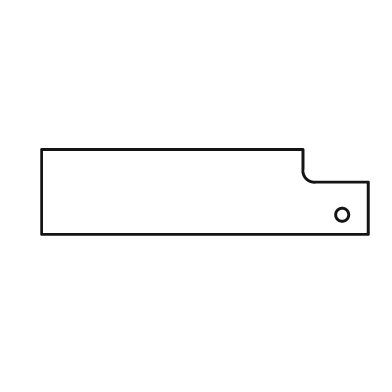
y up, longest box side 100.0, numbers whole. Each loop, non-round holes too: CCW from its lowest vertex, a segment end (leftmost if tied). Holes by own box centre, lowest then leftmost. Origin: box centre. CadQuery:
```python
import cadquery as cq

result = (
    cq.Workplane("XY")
    .moveTo(-50.0, -13.0)
    .lineTo(50.0, -13.0)
    .lineTo(50.0, 3.0)
    .lineTo(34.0, 3.0)
    .threePointArc((31.0, 4.0), (30.0, 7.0))
    .lineTo(30.0, 13.0)
    .lineTo(-50.0, 13.0)
    .close()
    .moveTo(42.0, -7.0)
    .circle(2.0)
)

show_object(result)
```